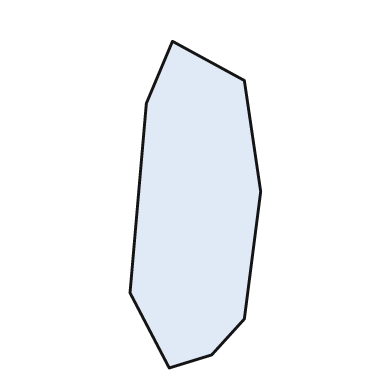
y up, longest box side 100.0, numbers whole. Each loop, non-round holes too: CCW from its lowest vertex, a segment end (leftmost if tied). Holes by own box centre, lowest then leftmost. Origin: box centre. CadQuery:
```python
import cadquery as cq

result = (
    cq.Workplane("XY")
    .moveTo(-8.0, -50.0)
    .lineTo(5.0, -46.0)
    .lineTo(15.0, -35.0)
    .lineTo(20.0, 4.0)
    .lineTo(15.0, 38.0)
    .lineTo(-7.0, 50.0)
    .lineTo(-15.0, 31.0)
    .lineTo(-20.0, -27.0)
    .close()
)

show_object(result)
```